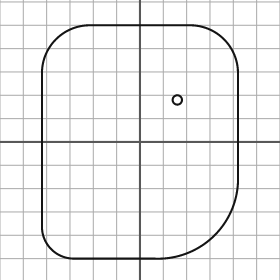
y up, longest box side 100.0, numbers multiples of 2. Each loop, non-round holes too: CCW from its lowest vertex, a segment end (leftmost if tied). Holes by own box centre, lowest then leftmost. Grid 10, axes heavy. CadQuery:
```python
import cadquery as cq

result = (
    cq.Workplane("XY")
    .moveTo(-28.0, -50.0)
    .lineTo(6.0, -50.0)
    .threePointArc((32.0, -40.0), (42.0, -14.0))
    .lineTo(42.0, 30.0)
    .threePointArc((36.0, 44.0), (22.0, 50.0))
    .lineTo(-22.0, 50.0)
    .threePointArc((-36.0, 44.0), (-42.0, 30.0))
    .lineTo(-42.0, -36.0)
    .threePointArc((-38.0, -46.0), (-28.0, -50.0))
    .close()
    .moveTo(16.0, 18.0)
    .circle(2.0)
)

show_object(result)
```